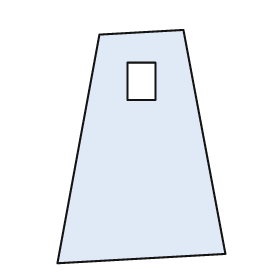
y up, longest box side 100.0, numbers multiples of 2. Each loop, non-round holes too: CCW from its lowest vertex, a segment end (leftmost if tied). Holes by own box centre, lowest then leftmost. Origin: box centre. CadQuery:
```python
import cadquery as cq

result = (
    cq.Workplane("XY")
    .moveTo(-36.0, -50.0)
    .lineTo(36.0, -46.0)
    .lineTo(18.0, 50.0)
    .lineTo(-18.0, 48.0)
    .close()
    .moveTo(-6.0, 20.0)
    .lineTo(6.0, 20.0)
    .lineTo(6.0, 36.0)
    .lineTo(-6.0, 36.0)
    .close()
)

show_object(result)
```